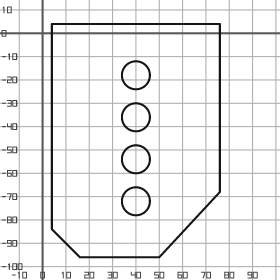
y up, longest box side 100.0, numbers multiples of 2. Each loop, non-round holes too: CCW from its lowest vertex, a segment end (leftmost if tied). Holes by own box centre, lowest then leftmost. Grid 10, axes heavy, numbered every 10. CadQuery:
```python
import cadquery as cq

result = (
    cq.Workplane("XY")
    .moveTo(16.0, -96.0)
    .lineTo(50.0, -96.0)
    .lineTo(76.0, -68.0)
    .lineTo(76.0, 4.0)
    .lineTo(4.0, 4.0)
    .lineTo(4.0, -84.0)
    .close()
    .moveTo(40.0, -72.0)
    .circle(6.0)
    .moveTo(40.0, -54.0)
    .circle(6.0)
    .moveTo(40.0, -36.0)
    .circle(6.0)
    .moveTo(40.0, -18.0)
    .circle(6.0)
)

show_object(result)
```